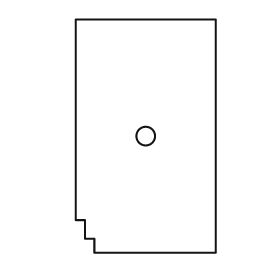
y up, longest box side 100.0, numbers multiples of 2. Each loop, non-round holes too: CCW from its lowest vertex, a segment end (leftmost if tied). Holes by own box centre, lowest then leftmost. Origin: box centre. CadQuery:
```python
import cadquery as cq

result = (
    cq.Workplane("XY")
    .moveTo(-22.0, -50.0)
    .lineTo(30.0, -50.0)
    .lineTo(30.0, 50.0)
    .lineTo(-30.0, 50.0)
    .lineTo(-30.0, -36.0)
    .lineTo(-26.0, -36.0)
    .lineTo(-26.0, -44.0)
    .lineTo(-22.0, -44.0)
    .close()
    .moveTo(0.0, 0.0)
    .circle(4.0)
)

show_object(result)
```